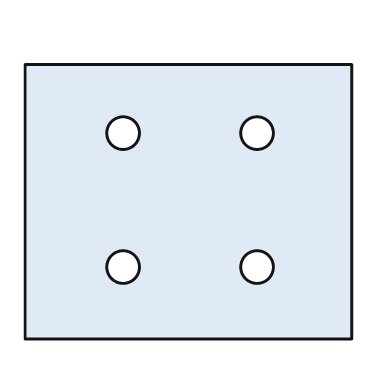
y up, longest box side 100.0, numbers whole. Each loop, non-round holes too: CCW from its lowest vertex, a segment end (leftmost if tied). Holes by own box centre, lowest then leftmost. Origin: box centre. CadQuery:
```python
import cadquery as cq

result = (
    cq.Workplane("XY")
    .moveTo(-50.0, -42.0)
    .lineTo(50.0, -42.0)
    .lineTo(50.0, 42.0)
    .lineTo(-50.0, 42.0)
    .close()
    .moveTo(-20.0, -20.0)
    .circle(5.0)
    .moveTo(21.0, -20.0)
    .circle(5.0)
    .moveTo(-20.0, 21.0)
    .circle(5.0)
    .moveTo(21.0, 21.0)
    .circle(5.0)
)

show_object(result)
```